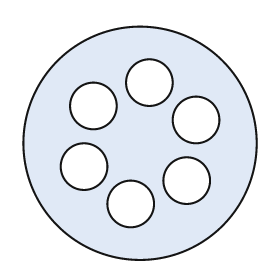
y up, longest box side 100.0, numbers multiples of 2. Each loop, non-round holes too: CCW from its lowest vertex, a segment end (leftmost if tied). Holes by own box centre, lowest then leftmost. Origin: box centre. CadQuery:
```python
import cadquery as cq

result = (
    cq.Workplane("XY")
    .moveTo(0.0, 0.0)
    .circle(50.0)
    .moveTo(-4.0, -26.0)
    .circle(10.0)
    .moveTo(20.0, -16.0)
    .circle(10.0)
    .moveTo(-24.0, -10.0)
    .circle(10.0)
    .moveTo(24.0, 10.0)
    .circle(10.0)
    .moveTo(-20.0, 16.0)
    .circle(10.0)
    .moveTo(4.0, 26.0)
    .circle(10.0)
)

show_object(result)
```